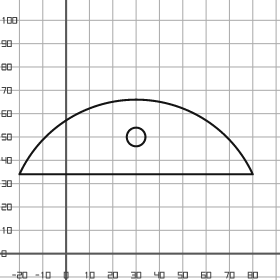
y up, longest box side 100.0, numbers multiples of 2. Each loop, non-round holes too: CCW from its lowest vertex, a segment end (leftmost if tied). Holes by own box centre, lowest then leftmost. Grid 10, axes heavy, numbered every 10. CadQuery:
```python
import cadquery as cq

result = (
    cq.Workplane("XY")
    .moveTo(-20.0, 34.0)
    .lineTo(80.0, 34.0)
    .threePointArc((30.0, 66.0), (-20.0, 34.0))
    .close()
    .moveTo(30.0, 50.0)
    .circle(4.0)
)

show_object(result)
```